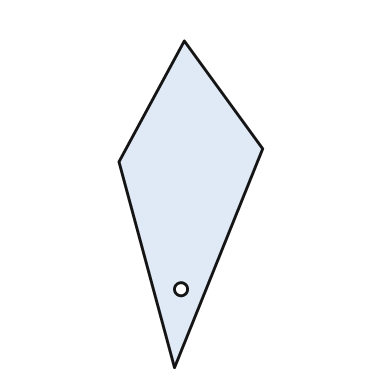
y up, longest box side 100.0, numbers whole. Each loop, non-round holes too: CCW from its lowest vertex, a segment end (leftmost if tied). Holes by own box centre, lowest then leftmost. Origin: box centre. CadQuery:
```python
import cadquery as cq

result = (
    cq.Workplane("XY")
    .moveTo(-5.0, -50.0)
    .lineTo(22.0, 17.0)
    .lineTo(-2.0, 50.0)
    .lineTo(-22.0, 13.0)
    .close()
    .moveTo(-3.0, -26.0)
    .circle(2.0)
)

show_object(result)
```